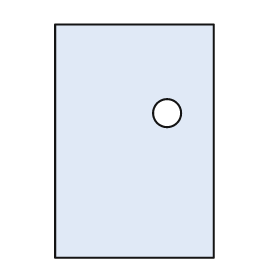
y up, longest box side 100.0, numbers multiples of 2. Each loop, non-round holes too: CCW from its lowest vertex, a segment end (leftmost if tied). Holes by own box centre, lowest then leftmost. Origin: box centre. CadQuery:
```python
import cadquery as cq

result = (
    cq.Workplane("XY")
    .moveTo(-34.0, -50.0)
    .lineTo(34.0, -50.0)
    .lineTo(34.0, 50.0)
    .lineTo(-34.0, 50.0)
    .close()
    .moveTo(14.0, 12.0)
    .circle(6.0)
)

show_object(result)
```